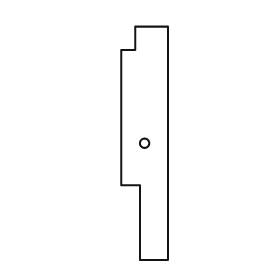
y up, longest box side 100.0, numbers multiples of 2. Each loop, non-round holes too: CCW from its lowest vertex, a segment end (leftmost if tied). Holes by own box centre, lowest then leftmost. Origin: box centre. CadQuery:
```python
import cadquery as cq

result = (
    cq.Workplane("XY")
    .moveTo(-2.0, -50.0)
    .lineTo(10.0, -50.0)
    .lineTo(10.0, 50.0)
    .lineTo(-4.0, 50.0)
    .lineTo(-4.0, 40.0)
    .lineTo(-10.0, 40.0)
    .lineTo(-10.0, -18.0)
    .lineTo(-2.0, -18.0)
    .close()
    .moveTo(0.0, 0.0)
    .circle(2.0)
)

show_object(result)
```